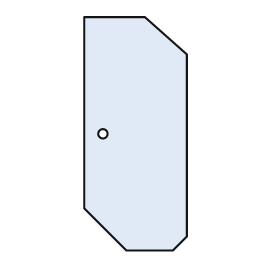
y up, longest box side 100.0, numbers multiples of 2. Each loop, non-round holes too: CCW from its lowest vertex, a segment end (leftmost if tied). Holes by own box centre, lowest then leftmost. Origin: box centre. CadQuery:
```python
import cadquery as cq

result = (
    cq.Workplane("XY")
    .moveTo(-4.0, -50.0)
    .lineTo(16.0, -50.0)
    .lineTo(22.0, -44.0)
    .lineTo(22.0, 34.0)
    .lineTo(4.0, 50.0)
    .lineTo(-22.0, 50.0)
    .lineTo(-22.0, -32.0)
    .close()
    .moveTo(-14.0, 0.0)
    .circle(2.0)
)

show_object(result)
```